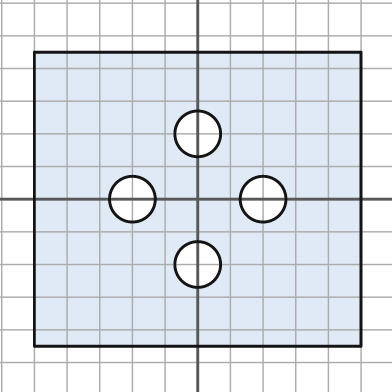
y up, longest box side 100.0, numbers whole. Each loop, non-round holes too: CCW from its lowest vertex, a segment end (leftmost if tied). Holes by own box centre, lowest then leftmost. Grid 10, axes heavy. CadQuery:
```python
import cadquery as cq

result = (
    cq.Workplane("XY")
    .moveTo(-50.0, -45.0)
    .lineTo(50.0, -45.0)
    .lineTo(50.0, 45.0)
    .lineTo(-50.0, 45.0)
    .close()
    .moveTo(0.0, -20.0)
    .circle(7.0)
    .moveTo(-20.0, 0.0)
    .circle(7.0)
    .moveTo(20.0, 0.0)
    .circle(7.0)
    .moveTo(0.0, 20.0)
    .circle(7.0)
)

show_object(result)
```